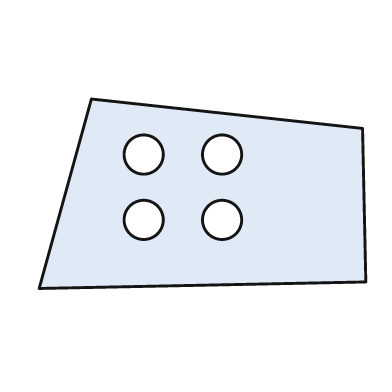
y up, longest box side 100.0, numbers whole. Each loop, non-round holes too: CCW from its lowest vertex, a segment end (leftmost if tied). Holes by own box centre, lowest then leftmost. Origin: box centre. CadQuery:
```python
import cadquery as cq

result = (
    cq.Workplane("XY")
    .moveTo(-50.0, -29.0)
    .lineTo(50.0, -27.0)
    .lineTo(49.0, 20.0)
    .lineTo(-34.0, 29.0)
    .close()
    .moveTo(-18.0, -8.0)
    .circle(6.0)
    .moveTo(6.0, -8.0)
    .circle(6.0)
    .moveTo(-18.0, 12.0)
    .circle(6.0)
    .moveTo(6.0, 12.0)
    .circle(6.0)
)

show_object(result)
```